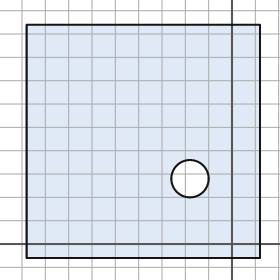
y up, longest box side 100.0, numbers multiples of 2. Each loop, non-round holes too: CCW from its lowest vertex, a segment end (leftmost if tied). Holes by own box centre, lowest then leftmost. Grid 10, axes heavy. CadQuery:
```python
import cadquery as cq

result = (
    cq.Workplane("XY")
    .moveTo(-88.0, -6.0)
    .lineTo(12.0, -6.0)
    .lineTo(12.0, 94.0)
    .lineTo(-88.0, 94.0)
    .close()
    .moveTo(-18.0, 28.0)
    .circle(8.0)
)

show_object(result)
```